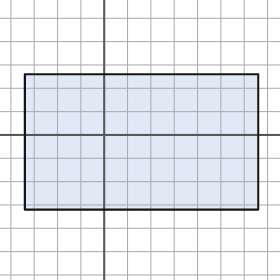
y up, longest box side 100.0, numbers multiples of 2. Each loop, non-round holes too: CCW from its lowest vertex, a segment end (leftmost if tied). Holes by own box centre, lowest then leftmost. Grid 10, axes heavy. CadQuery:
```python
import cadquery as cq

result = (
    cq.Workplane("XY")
    .moveTo(-34.0, -32.0)
    .lineTo(66.0, -32.0)
    .lineTo(66.0, 26.0)
    .lineTo(-34.0, 26.0)
    .close()
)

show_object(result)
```